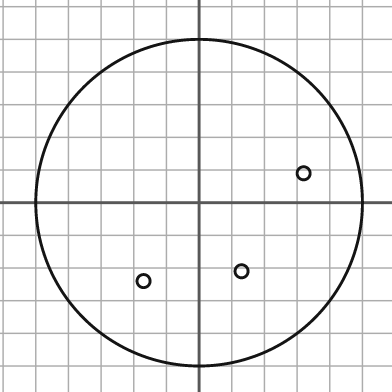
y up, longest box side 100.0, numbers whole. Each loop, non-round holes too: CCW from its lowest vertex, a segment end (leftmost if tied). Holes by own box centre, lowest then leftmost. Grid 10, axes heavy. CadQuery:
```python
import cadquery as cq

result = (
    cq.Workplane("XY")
    .moveTo(0.0, 0.0)
    .circle(50.0)
    .moveTo(-17.0, -24.0)
    .circle(2.0)
    .moveTo(13.0, -21.0)
    .circle(2.0)
    .moveTo(32.0, 9.0)
    .circle(2.0)
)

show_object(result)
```